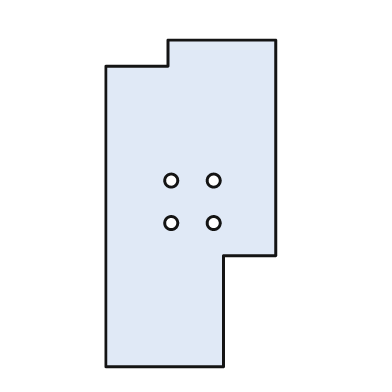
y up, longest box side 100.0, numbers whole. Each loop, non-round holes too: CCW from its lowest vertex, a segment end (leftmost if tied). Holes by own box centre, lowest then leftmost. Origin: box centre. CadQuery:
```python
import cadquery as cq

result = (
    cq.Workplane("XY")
    .moveTo(-26.0, -50.0)
    .lineTo(10.0, -50.0)
    .lineTo(10.0, -16.0)
    .lineTo(26.0, -16.0)
    .lineTo(26.0, 50.0)
    .lineTo(-7.0, 50.0)
    .lineTo(-7.0, 42.0)
    .lineTo(-26.0, 42.0)
    .close()
    .moveTo(-6.0, -6.0)
    .circle(2.0)
    .moveTo(7.0, -6.0)
    .circle(2.0)
    .moveTo(-6.0, 7.0)
    .circle(2.0)
    .moveTo(7.0, 7.0)
    .circle(2.0)
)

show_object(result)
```